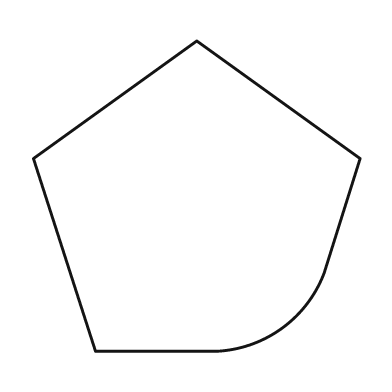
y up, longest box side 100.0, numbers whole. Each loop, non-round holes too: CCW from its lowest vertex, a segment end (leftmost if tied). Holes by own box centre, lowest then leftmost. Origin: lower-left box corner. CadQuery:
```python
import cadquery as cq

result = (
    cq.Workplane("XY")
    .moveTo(19.0, 0.0)
    .lineTo(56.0, 0.0)
    .threePointArc((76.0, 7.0), (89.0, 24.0))
    .lineTo(100.0, 59.0)
    .lineTo(50.0, 95.0)
    .lineTo(0.0, 59.0)
    .close()
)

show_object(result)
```